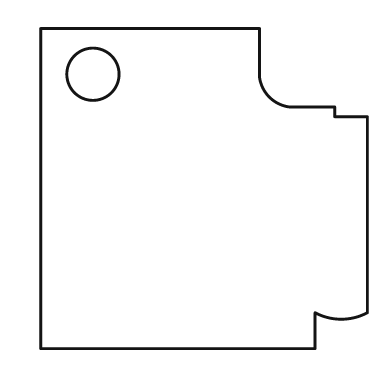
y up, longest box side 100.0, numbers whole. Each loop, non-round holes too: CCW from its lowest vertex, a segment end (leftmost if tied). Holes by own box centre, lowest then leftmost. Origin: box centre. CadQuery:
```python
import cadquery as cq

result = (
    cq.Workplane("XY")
    .moveTo(-50.0, -49.0)
    .lineTo(34.0, -49.0)
    .lineTo(34.0, -38.0)
    .threePointArc((42.0, -40.0), (50.0, -38.0))
    .lineTo(50.0, 22.0)
    .lineTo(40.0, 22.0)
    .lineTo(40.0, 25.0)
    .lineTo(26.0, 25.0)
    .threePointArc((20.0, 28.0), (17.0, 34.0))
    .lineTo(17.0, 49.0)
    .lineTo(-50.0, 49.0)
    .close()
    .moveTo(-34.0, 35.0)
    .circle(8.0)
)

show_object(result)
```